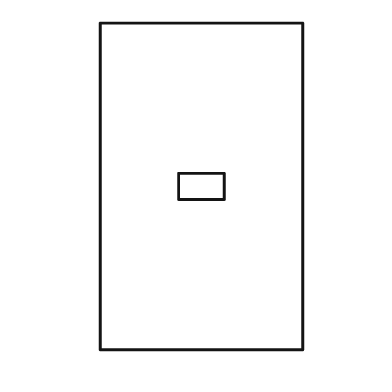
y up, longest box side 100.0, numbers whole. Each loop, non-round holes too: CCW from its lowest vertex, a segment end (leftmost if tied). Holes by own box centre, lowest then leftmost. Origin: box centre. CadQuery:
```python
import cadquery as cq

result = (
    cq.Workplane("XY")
    .moveTo(-31.0, -50.0)
    .lineTo(31.0, -50.0)
    .lineTo(31.0, 50.0)
    .lineTo(-31.0, 50.0)
    .close()
    .moveTo(-7.0, -4.0)
    .lineTo(7.0, -4.0)
    .lineTo(7.0, 4.0)
    .lineTo(-7.0, 4.0)
    .close()
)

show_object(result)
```